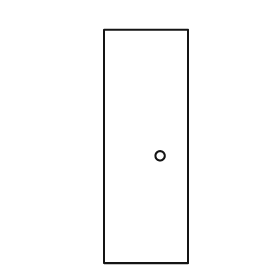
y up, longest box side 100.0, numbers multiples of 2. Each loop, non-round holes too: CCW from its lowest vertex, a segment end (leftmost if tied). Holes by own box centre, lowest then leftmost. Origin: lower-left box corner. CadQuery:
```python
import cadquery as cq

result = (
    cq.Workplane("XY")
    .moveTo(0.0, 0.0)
    .lineTo(36.0, 0.0)
    .lineTo(36.0, 100.0)
    .lineTo(0.0, 100.0)
    .close()
    .moveTo(24.0, 46.0)
    .circle(2.0)
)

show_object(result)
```